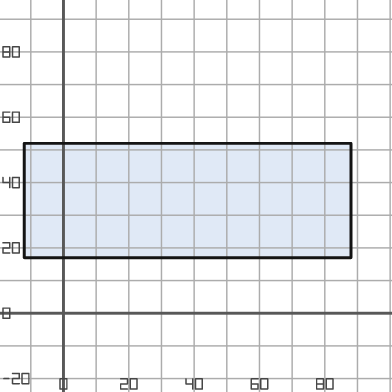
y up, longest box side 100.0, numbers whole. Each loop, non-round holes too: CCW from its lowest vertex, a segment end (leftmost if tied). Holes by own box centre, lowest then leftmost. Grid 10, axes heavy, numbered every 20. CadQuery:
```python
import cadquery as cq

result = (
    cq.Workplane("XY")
    .moveTo(-12.0, 17.0)
    .lineTo(88.0, 17.0)
    .lineTo(88.0, 52.0)
    .lineTo(-12.0, 52.0)
    .close()
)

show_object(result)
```